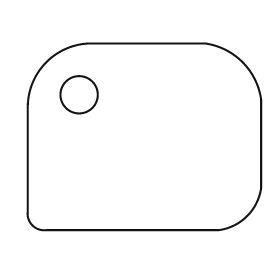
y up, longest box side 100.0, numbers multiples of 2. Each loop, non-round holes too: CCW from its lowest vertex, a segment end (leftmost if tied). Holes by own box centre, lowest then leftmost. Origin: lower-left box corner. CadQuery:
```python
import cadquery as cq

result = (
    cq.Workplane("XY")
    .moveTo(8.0, 0.0)
    .lineTo(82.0, 0.0)
    .threePointArc((94.0, 6.0), (100.0, 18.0))
    .lineTo(100.0, 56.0)
    .threePointArc((92.0, 72.0), (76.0, 80.0))
    .lineTo(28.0, 80.0)
    .threePointArc((8.0, 72.0), (0.0, 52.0))
    .lineTo(0.0, 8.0)
    .threePointArc((2.0, 2.0), (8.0, 0.0))
    .close()
    .moveTo(22.0, 58.0)
    .circle(8.0)
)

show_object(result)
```